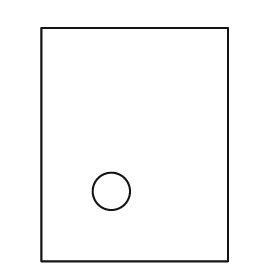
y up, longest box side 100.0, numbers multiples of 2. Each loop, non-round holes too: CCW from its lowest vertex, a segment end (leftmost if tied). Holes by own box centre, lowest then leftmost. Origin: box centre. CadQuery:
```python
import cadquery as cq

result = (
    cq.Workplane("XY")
    .moveTo(-40.0, -50.0)
    .lineTo(40.0, -50.0)
    .lineTo(40.0, 50.0)
    .lineTo(-40.0, 50.0)
    .close()
    .moveTo(-10.0, -20.0)
    .circle(8.0)
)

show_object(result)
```